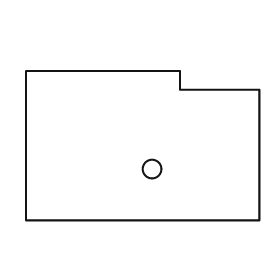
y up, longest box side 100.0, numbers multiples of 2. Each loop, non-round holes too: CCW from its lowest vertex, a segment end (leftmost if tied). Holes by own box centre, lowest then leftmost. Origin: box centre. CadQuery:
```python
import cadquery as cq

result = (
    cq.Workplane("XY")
    .moveTo(-50.0, -32.0)
    .lineTo(50.0, -32.0)
    .lineTo(50.0, 24.0)
    .lineTo(16.0, 24.0)
    .lineTo(16.0, 32.0)
    .lineTo(-50.0, 32.0)
    .close()
    .moveTo(4.0, -10.0)
    .circle(4.0)
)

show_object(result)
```